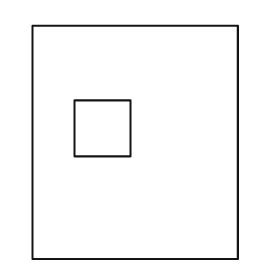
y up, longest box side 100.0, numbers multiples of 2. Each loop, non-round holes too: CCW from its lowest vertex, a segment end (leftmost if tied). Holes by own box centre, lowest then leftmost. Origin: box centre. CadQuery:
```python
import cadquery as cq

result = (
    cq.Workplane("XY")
    .moveTo(-44.0, -50.0)
    .lineTo(44.0, -50.0)
    .lineTo(44.0, 50.0)
    .lineTo(-44.0, 50.0)
    .close()
    .moveTo(-26.0, -6.0)
    .lineTo(-2.0, -6.0)
    .lineTo(-2.0, 18.0)
    .lineTo(-26.0, 18.0)
    .close()
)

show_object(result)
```